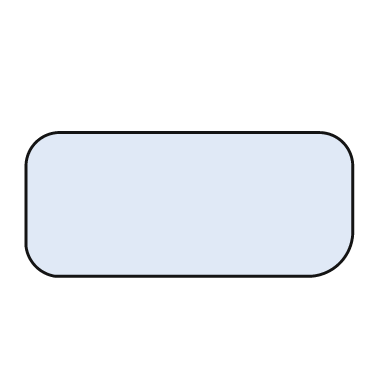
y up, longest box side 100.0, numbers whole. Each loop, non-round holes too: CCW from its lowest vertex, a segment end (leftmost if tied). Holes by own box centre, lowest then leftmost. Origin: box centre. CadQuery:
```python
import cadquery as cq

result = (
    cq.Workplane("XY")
    .moveTo(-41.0, -22.0)
    .lineTo(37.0, -22.0)
    .threePointArc((46.0, -18.0), (50.0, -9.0))
    .lineTo(50.0, 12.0)
    .threePointArc((47.0, 19.0), (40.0, 22.0))
    .lineTo(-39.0, 22.0)
    .threePointArc((-47.0, 19.0), (-50.0, 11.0))
    .lineTo(-50.0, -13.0)
    .threePointArc((-47.0, -19.0), (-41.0, -22.0))
    .close()
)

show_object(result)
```